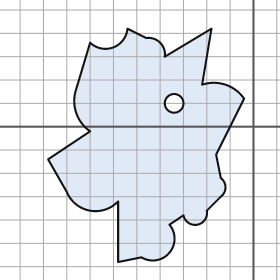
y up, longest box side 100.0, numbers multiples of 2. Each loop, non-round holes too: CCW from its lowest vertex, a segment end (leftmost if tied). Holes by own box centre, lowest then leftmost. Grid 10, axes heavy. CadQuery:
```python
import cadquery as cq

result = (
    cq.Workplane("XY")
    .moveTo(-58.0, -58.0)
    .lineTo(-48.0, -56.0)
    .threePointArc((-36.0, -54.0), (-36.0, -42.0))
    .lineTo(-30.0, -38.0)
    .threePointArc((-24.0, -42.0), (-20.0, -36.0))
    .lineTo(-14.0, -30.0)
    .threePointArc((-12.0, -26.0), (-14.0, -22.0))
    .lineTo(-16.0, -12.0)
    .lineTo(-4.0, 12.0)
    .threePointArc((-12.0, 18.0), (-22.0, 18.0))
    .lineTo(-18.0, 42.0)
    .lineTo(-38.0, 30.0)
    .threePointArc((-40.0, 36.0), (-46.0, 38.0))
    .lineTo(-54.0, 42.0)
    .threePointArc((-60.0, 34.0), (-70.0, 36.0))
    .lineTo(-76.0, 16.0)
    .threePointArc((-76.0, 6.0), (-70.0, -2.0))
    .lineTo(-88.0, -14.0)
    .lineTo(-80.0, -28.0)
    .threePointArc((-70.0, -36.0), (-58.0, -32.0))
    .close()
    .moveTo(-34.0, 10.0)
    .circle(4.0)
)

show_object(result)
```